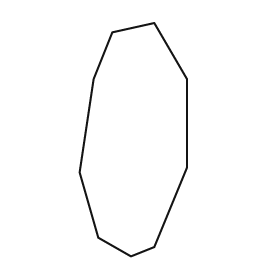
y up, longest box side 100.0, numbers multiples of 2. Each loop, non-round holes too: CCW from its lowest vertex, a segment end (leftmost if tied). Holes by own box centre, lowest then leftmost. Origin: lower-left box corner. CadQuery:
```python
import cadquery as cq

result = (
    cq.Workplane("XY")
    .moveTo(22.0, 0.0)
    .lineTo(32.0, 4.0)
    .lineTo(46.0, 38.0)
    .lineTo(46.0, 76.0)
    .lineTo(32.0, 100.0)
    .lineTo(14.0, 96.0)
    .lineTo(6.0, 76.0)
    .lineTo(0.0, 36.0)
    .lineTo(8.0, 8.0)
    .close()
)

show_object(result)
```